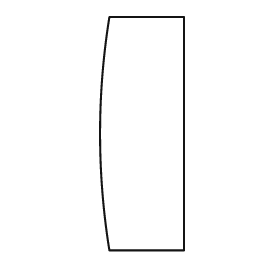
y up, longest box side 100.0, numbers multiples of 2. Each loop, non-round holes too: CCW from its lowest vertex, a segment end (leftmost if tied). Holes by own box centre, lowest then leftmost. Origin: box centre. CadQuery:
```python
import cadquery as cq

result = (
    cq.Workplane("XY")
    .moveTo(-14.0, -50.0)
    .lineTo(18.0, -50.0)
    .lineTo(18.0, 50.0)
    .lineTo(-14.0, 50.0)
    .threePointArc((-18.0, 0.0), (-14.0, -50.0))
    .close()
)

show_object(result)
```